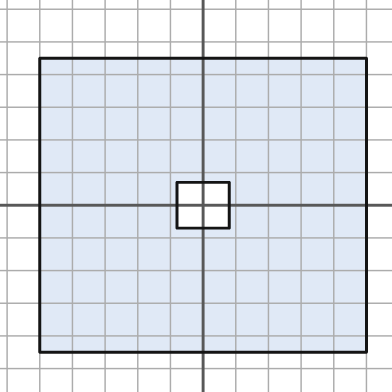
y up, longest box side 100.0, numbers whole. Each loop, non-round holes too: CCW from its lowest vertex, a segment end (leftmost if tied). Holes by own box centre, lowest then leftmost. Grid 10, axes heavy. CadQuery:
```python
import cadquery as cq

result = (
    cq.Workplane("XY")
    .moveTo(-50.0, -45.0)
    .lineTo(50.0, -45.0)
    .lineTo(50.0, 45.0)
    .lineTo(-50.0, 45.0)
    .close()
    .moveTo(-8.0, -7.0)
    .lineTo(8.0, -7.0)
    .lineTo(8.0, 7.0)
    .lineTo(-8.0, 7.0)
    .close()
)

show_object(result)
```